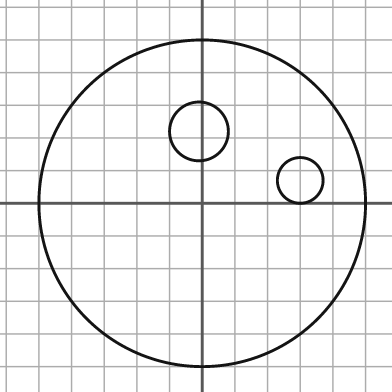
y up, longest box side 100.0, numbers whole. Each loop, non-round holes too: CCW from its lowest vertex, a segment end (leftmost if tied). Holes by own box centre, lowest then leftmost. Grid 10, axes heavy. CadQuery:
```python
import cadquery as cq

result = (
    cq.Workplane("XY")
    .moveTo(0.0, 0.0)
    .circle(50.0)
    .moveTo(30.0, 7.0)
    .circle(7.0)
    .moveTo(-1.0, 22.0)
    .circle(9.0)
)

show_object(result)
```